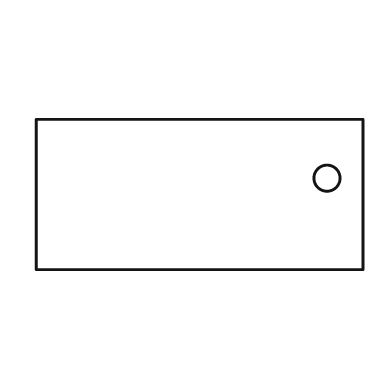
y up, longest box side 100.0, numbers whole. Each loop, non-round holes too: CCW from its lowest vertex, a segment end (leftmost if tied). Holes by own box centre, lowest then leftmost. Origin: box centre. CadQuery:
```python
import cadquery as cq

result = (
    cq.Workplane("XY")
    .moveTo(-50.0, -23.0)
    .lineTo(50.0, -23.0)
    .lineTo(50.0, 23.0)
    .lineTo(-50.0, 23.0)
    .close()
    .moveTo(39.0, 5.0)
    .circle(4.0)
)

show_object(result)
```